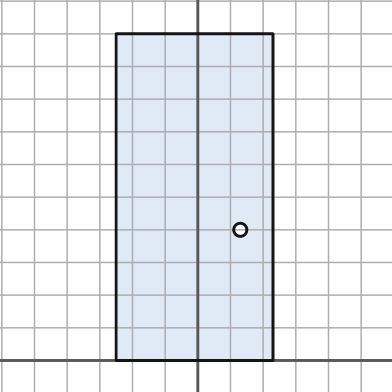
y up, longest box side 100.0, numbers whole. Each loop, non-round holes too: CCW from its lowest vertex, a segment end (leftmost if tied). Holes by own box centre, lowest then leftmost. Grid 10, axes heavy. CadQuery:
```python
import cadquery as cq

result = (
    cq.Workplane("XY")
    .moveTo(-25.0, 0.0)
    .lineTo(23.0, 0.0)
    .lineTo(23.0, 100.0)
    .lineTo(-25.0, 100.0)
    .close()
    .moveTo(13.0, 40.0)
    .circle(2.0)
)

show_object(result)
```